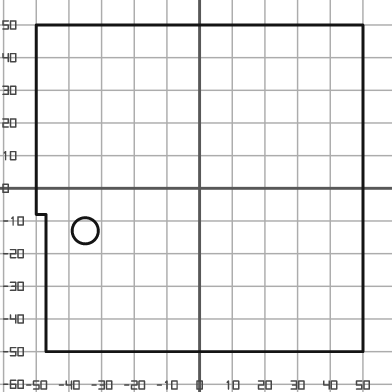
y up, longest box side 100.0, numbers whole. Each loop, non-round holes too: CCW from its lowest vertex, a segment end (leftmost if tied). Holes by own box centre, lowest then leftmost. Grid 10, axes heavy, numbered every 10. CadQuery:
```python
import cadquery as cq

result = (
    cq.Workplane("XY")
    .moveTo(-47.0, -50.0)
    .lineTo(50.0, -50.0)
    .lineTo(50.0, 50.0)
    .lineTo(-50.0, 50.0)
    .lineTo(-50.0, -8.0)
    .lineTo(-47.0, -8.0)
    .close()
    .moveTo(-35.0, -13.0)
    .circle(4.0)
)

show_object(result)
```